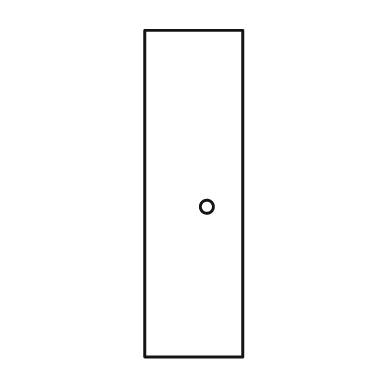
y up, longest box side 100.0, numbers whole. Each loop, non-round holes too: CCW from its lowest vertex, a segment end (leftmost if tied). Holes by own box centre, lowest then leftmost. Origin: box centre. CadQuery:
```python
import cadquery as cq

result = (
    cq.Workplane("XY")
    .moveTo(-15.0, -50.0)
    .lineTo(15.0, -50.0)
    .lineTo(15.0, 50.0)
    .lineTo(-15.0, 50.0)
    .close()
    .moveTo(4.0, -4.0)
    .circle(2.0)
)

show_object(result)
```